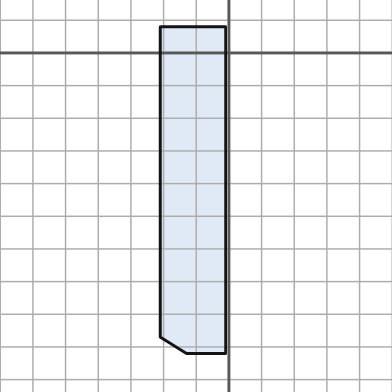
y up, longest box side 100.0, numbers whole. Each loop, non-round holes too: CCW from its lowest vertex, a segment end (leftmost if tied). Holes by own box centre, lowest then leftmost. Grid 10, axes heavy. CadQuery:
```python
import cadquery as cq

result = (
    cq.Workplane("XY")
    .moveTo(-13.0, -92.0)
    .lineTo(-1.0, -92.0)
    .lineTo(-1.0, 8.0)
    .lineTo(-21.0, 8.0)
    .lineTo(-21.0, -87.0)
    .close()
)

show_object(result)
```